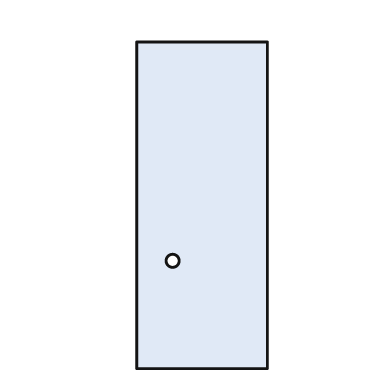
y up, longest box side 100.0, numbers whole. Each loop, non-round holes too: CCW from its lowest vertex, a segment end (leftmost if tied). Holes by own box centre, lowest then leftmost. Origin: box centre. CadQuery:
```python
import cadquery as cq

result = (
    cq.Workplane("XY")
    .moveTo(-20.0, -50.0)
    .lineTo(20.0, -50.0)
    .lineTo(20.0, 50.0)
    .lineTo(-20.0, 50.0)
    .close()
    .moveTo(-9.0, -17.0)
    .circle(2.0)
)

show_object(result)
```